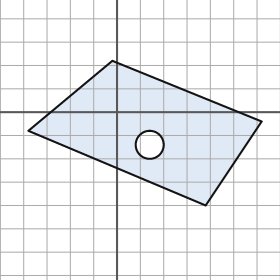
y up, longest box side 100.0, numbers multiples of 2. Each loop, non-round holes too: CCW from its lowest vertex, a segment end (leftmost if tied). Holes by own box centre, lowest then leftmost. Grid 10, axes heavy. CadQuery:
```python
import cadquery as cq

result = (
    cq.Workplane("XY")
    .moveTo(38.0, -40.0)
    .lineTo(62.0, -4.0)
    .lineTo(-2.0, 22.0)
    .lineTo(-38.0, -8.0)
    .close()
    .moveTo(14.0, -14.0)
    .circle(6.0)
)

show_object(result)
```